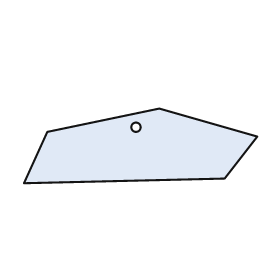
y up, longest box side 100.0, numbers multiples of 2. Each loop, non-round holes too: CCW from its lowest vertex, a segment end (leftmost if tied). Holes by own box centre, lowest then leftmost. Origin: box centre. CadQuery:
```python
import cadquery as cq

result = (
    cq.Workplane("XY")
    .moveTo(-50.0, -16.0)
    .lineTo(36.0, -14.0)
    .lineTo(50.0, 4.0)
    .lineTo(8.0, 16.0)
    .lineTo(-40.0, 6.0)
    .close()
    .moveTo(-2.0, 8.0)
    .circle(2.0)
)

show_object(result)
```